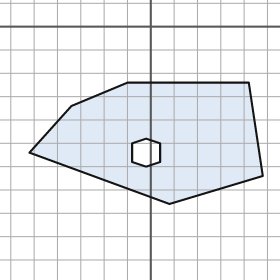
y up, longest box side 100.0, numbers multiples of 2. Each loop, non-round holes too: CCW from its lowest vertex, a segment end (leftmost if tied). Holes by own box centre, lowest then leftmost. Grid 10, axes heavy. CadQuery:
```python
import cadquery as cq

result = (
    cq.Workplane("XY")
    .moveTo(8.0, -76.0)
    .lineTo(48.0, -64.0)
    .lineTo(42.0, -24.0)
    .lineTo(-10.0, -24.0)
    .lineTo(-34.0, -34.0)
    .lineTo(-52.0, -54.0)
    .close()
    .moveTo(-2.0, -60.0)
    .lineTo(4.0, -58.0)
    .lineTo(4.0, -50.0)
    .lineTo(-2.0, -48.0)
    .lineTo(-8.0, -50.0)
    .lineTo(-8.0, -58.0)
    .close()
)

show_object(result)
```